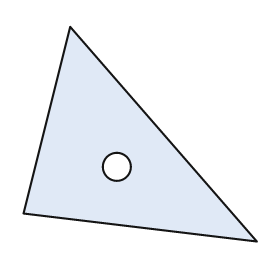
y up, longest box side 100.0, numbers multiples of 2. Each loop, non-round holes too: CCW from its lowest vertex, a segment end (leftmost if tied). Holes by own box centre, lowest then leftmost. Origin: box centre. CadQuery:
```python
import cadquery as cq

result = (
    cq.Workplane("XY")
    .moveTo(50.0, -46.0)
    .lineTo(-30.0, 46.0)
    .lineTo(-50.0, -34.0)
    .close()
    .moveTo(-10.0, -14.0)
    .circle(6.0)
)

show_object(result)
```